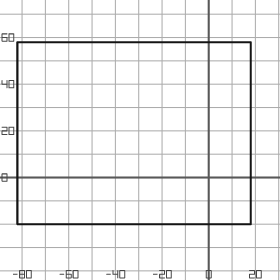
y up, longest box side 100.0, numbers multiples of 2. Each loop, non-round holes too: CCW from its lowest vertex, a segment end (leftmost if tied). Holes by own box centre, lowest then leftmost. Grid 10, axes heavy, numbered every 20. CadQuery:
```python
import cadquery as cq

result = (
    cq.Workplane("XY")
    .moveTo(-82.0, -20.0)
    .lineTo(18.0, -20.0)
    .lineTo(18.0, 58.0)
    .lineTo(-82.0, 58.0)
    .close()
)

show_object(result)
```